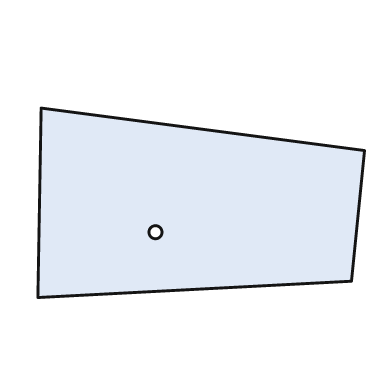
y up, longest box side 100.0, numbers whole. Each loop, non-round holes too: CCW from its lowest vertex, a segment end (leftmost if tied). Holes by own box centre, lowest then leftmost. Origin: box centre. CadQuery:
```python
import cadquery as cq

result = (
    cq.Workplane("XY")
    .moveTo(-50.0, -29.0)
    .lineTo(46.0, -24.0)
    .lineTo(50.0, 16.0)
    .lineTo(-49.0, 29.0)
    .close()
    .moveTo(-14.0, -9.0)
    .circle(2.0)
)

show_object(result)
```